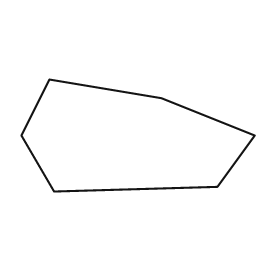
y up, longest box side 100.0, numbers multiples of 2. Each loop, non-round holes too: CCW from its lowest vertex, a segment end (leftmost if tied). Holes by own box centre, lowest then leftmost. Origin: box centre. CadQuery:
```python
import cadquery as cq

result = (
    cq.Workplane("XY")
    .moveTo(-36.0, -24.0)
    .lineTo(34.0, -22.0)
    .lineTo(50.0, 0.0)
    .lineTo(10.0, 16.0)
    .lineTo(-38.0, 24.0)
    .lineTo(-50.0, 0.0)
    .close()
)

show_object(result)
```